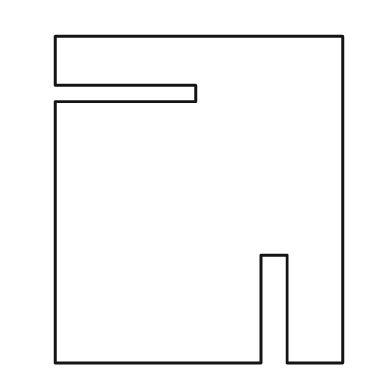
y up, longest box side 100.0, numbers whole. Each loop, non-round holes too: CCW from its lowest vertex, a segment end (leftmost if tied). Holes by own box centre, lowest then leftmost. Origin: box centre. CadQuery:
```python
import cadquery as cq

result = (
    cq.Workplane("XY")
    .moveTo(-44.0, -50.0)
    .lineTo(19.0, -50.0)
    .lineTo(19.0, -17.0)
    .lineTo(27.0, -17.0)
    .lineTo(27.0, -50.0)
    .lineTo(44.0, -50.0)
    .lineTo(44.0, 50.0)
    .lineTo(-44.0, 50.0)
    .lineTo(-44.0, 35.0)
    .lineTo(-1.0, 35.0)
    .lineTo(-1.0, 30.0)
    .lineTo(-44.0, 30.0)
    .close()
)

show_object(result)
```